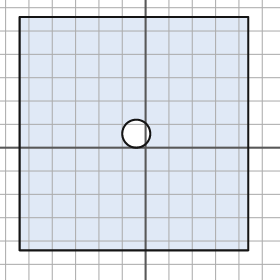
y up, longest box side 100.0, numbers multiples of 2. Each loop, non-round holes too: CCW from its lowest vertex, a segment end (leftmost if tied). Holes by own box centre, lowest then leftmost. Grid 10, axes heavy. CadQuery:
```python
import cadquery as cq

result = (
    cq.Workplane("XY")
    .moveTo(-54.0, -44.0)
    .lineTo(44.0, -44.0)
    .lineTo(44.0, 56.0)
    .lineTo(-54.0, 56.0)
    .close()
    .moveTo(-4.0, 6.0)
    .circle(6.0)
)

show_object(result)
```